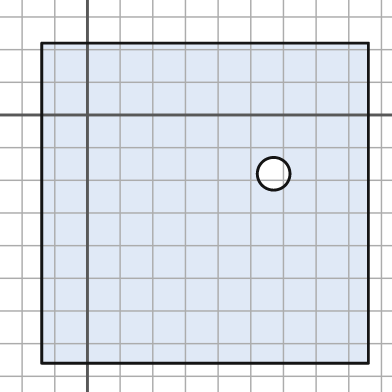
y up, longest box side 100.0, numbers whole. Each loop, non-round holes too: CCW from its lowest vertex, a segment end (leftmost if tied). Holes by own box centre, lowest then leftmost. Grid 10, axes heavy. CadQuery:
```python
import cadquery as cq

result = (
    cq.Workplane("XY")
    .moveTo(-14.0, -76.0)
    .lineTo(86.0, -76.0)
    .lineTo(86.0, 22.0)
    .lineTo(-14.0, 22.0)
    .close()
    .moveTo(57.0, -18.0)
    .circle(5.0)
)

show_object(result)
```